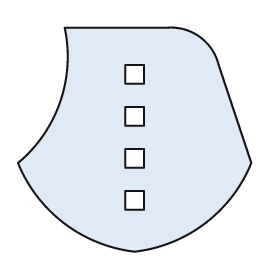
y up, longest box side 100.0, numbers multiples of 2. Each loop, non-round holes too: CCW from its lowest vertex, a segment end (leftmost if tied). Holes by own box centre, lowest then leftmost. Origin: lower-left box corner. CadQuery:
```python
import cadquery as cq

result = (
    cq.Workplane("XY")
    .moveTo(50.0, 0.0)
    .threePointArc((80.0, 12.0), (100.0, 38.0))
    .lineTo(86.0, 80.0)
    .threePointArc((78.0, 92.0), (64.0, 96.0))
    .lineTo(20.0, 96.0)
    .threePointArc((18.0, 64.0), (0.0, 38.0))
    .threePointArc((20.0, 12.0), (50.0, 0.0))
    .close()
    .moveTo(46.0, 18.0)
    .lineTo(54.0, 18.0)
    .lineTo(54.0, 26.0)
    .lineTo(46.0, 26.0)
    .close()
    .moveTo(46.0, 36.0)
    .lineTo(54.0, 36.0)
    .lineTo(54.0, 44.0)
    .lineTo(46.0, 44.0)
    .close()
    .moveTo(46.0, 54.0)
    .lineTo(54.0, 54.0)
    .lineTo(54.0, 62.0)
    .lineTo(46.0, 62.0)
    .close()
    .moveTo(46.0, 72.0)
    .lineTo(54.0, 72.0)
    .lineTo(54.0, 80.0)
    .lineTo(46.0, 80.0)
    .close()
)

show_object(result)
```